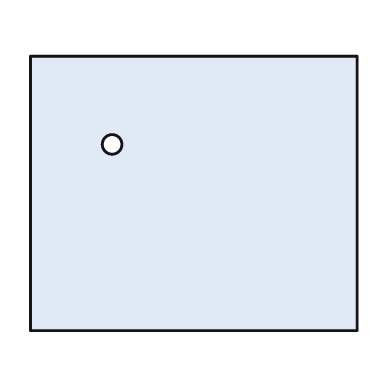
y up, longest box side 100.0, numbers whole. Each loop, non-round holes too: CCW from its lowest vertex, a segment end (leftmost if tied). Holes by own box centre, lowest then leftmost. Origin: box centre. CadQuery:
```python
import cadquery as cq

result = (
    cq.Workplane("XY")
    .moveTo(-50.0, -42.0)
    .lineTo(50.0, -42.0)
    .lineTo(50.0, 42.0)
    .lineTo(-50.0, 42.0)
    .close()
    .moveTo(-25.0, 15.0)
    .circle(3.0)
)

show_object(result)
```